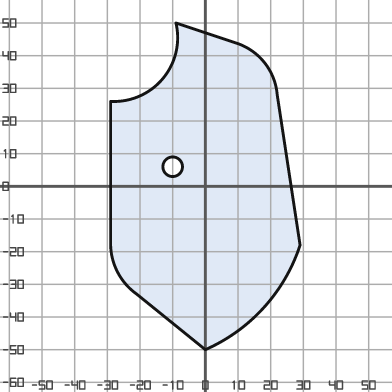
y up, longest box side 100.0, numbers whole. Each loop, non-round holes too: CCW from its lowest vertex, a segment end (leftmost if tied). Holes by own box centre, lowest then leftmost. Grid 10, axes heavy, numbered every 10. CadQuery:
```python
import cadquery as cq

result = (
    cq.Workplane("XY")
    .moveTo(0.0, -50.0)
    .threePointArc((18.0, -37.0), (29.0, -18.0))
    .lineTo(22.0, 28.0)
    .threePointArc((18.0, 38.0), (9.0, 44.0))
    .lineTo(-9.0, 50.0)
    .threePointArc((-13.0, 33.0), (-29.0, 26.0))
    .lineTo(-29.0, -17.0)
    .threePointArc((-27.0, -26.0), (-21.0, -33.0))
    .close()
    .moveTo(-10.0, 6.0)
    .circle(3.0)
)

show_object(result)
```